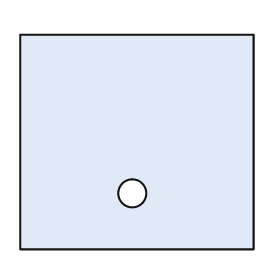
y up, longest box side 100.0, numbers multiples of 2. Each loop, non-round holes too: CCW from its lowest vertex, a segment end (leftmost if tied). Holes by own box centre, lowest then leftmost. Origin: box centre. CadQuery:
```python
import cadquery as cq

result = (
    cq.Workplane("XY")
    .moveTo(-50.0, -46.0)
    .lineTo(50.0, -46.0)
    .lineTo(50.0, 46.0)
    .lineTo(-50.0, 46.0)
    .close()
    .moveTo(-2.0, -22.0)
    .circle(6.0)
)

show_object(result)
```